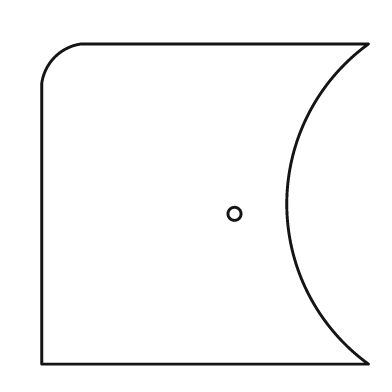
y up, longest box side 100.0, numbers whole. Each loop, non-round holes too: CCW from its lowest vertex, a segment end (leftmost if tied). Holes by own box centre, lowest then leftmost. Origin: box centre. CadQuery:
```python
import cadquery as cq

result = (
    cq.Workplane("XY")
    .moveTo(-50.0, -49.0)
    .lineTo(50.0, -49.0)
    .threePointArc((25.0, 0.0), (50.0, 49.0))
    .lineTo(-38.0, 49.0)
    .threePointArc((-46.0, 45.0), (-50.0, 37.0))
    .close()
    .moveTo(9.0, -3.0)
    .circle(2.0)
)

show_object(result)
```